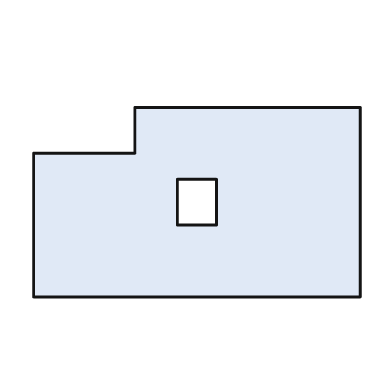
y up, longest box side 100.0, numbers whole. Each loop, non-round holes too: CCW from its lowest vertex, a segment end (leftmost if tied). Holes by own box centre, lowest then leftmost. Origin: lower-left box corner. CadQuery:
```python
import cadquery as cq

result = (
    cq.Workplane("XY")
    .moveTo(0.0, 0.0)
    .lineTo(100.0, 0.0)
    .lineTo(100.0, 58.0)
    .lineTo(31.0, 58.0)
    .lineTo(31.0, 44.0)
    .lineTo(0.0, 44.0)
    .close()
    .moveTo(44.0, 22.0)
    .lineTo(56.0, 22.0)
    .lineTo(56.0, 36.0)
    .lineTo(44.0, 36.0)
    .close()
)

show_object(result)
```